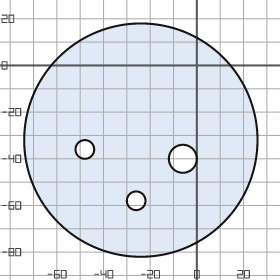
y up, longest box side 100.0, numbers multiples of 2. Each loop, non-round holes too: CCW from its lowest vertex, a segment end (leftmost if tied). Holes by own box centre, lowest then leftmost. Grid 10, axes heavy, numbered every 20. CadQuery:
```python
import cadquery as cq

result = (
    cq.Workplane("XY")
    .moveTo(-24.0, -32.0)
    .circle(50.0)
    .moveTo(-26.0, -58.0)
    .circle(4.0)
    .moveTo(-6.0, -40.0)
    .circle(6.0)
    .moveTo(-48.0, -36.0)
    .circle(4.0)
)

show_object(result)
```